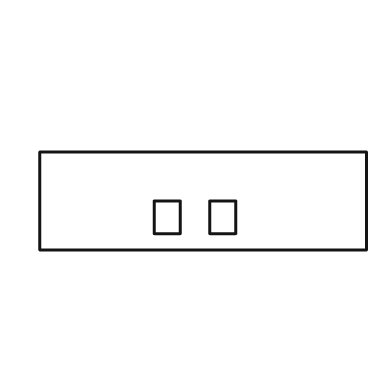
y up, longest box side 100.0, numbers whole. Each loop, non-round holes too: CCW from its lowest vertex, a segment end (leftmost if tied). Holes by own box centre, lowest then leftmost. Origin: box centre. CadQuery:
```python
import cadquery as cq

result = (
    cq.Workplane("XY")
    .moveTo(-50.0, -15.0)
    .lineTo(50.0, -15.0)
    .lineTo(50.0, 15.0)
    .lineTo(-50.0, 15.0)
    .close()
    .moveTo(-15.0, -10.0)
    .lineTo(-7.0, -10.0)
    .lineTo(-7.0, 0.0)
    .lineTo(-15.0, 0.0)
    .close()
    .moveTo(2.0, -10.0)
    .lineTo(10.0, -10.0)
    .lineTo(10.0, 0.0)
    .lineTo(2.0, 0.0)
    .close()
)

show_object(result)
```